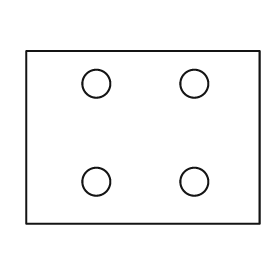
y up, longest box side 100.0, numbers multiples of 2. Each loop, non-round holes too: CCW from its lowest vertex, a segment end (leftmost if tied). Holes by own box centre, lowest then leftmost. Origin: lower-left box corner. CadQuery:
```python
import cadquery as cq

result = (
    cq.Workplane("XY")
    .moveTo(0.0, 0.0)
    .lineTo(100.0, 0.0)
    .lineTo(100.0, 74.0)
    .lineTo(0.0, 74.0)
    .close()
    .moveTo(30.0, 18.0)
    .circle(6.0)
    .moveTo(72.0, 18.0)
    .circle(6.0)
    .moveTo(30.0, 60.0)
    .circle(6.0)
    .moveTo(72.0, 60.0)
    .circle(6.0)
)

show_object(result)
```